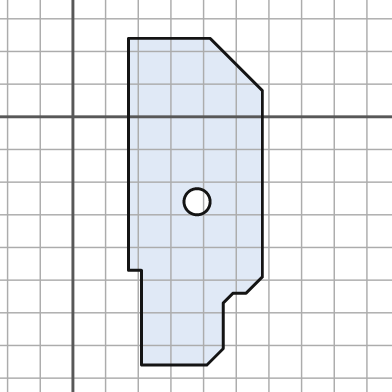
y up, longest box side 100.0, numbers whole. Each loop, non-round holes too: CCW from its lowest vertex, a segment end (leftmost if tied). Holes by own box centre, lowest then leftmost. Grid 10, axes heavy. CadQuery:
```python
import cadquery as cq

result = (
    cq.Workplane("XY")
    .moveTo(21.0, -76.0)
    .lineTo(41.0, -76.0)
    .lineTo(46.0, -71.0)
    .lineTo(46.0, -57.0)
    .lineTo(49.0, -54.0)
    .lineTo(53.0, -54.0)
    .lineTo(58.0, -49.0)
    .lineTo(58.0, 8.0)
    .lineTo(42.0, 24.0)
    .lineTo(17.0, 24.0)
    .lineTo(17.0, -47.0)
    .lineTo(21.0, -47.0)
    .close()
    .moveTo(38.0, -26.0)
    .circle(4.0)
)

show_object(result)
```